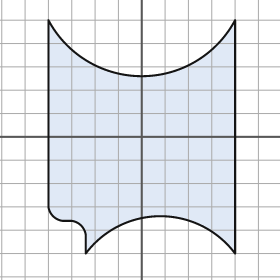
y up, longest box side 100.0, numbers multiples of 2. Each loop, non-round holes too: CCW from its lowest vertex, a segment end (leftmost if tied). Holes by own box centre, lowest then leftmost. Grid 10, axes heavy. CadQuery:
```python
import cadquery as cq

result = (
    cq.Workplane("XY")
    .moveTo(-24.0, -50.0)
    .threePointArc((8.0, -34.0), (40.0, -50.0))
    .lineTo(40.0, 50.0)
    .threePointArc((0.0, 26.0), (-40.0, 50.0))
    .lineTo(-40.0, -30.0)
    .threePointArc((-38.0, -34.0), (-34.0, -36.0))
    .lineTo(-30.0, -36.0)
    .threePointArc((-26.0, -38.0), (-24.0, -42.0))
    .close()
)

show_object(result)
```